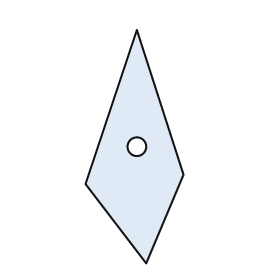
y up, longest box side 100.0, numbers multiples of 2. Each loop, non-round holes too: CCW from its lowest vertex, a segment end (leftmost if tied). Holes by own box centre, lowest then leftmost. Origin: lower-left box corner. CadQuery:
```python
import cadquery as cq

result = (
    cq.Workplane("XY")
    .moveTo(26.0, 0.0)
    .lineTo(42.0, 38.0)
    .lineTo(22.0, 100.0)
    .lineTo(0.0, 34.0)
    .close()
    .moveTo(22.0, 50.0)
    .circle(4.0)
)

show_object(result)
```